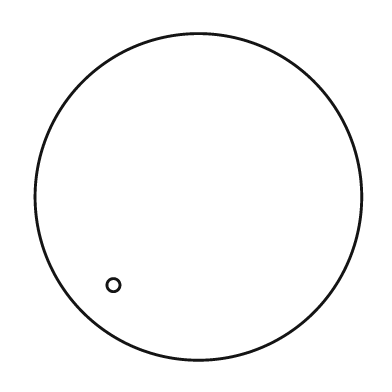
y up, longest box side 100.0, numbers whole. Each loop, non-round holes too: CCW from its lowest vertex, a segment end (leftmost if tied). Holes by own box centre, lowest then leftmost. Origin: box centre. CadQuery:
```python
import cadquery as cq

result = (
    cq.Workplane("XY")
    .moveTo(0.0, 0.0)
    .circle(50.0)
    .moveTo(-26.0, -27.0)
    .circle(2.0)
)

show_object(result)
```